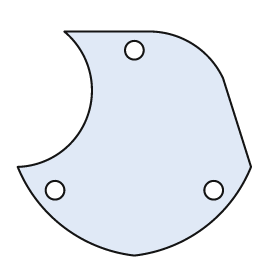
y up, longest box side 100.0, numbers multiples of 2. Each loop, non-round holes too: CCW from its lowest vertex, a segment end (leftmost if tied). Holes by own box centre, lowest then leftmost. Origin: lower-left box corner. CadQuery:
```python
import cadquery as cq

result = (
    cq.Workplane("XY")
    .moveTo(50.0, 0.0)
    .threePointArc((80.0, 12.0), (100.0, 38.0))
    .lineTo(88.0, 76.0)
    .threePointArc((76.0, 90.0), (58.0, 96.0))
    .lineTo(20.0, 96.0)
    .threePointArc((30.0, 60.0), (0.0, 38.0))
    .threePointArc((20.0, 12.0), (50.0, 0.0))
    .close()
    .moveTo(16.0, 28.0)
    .circle(4.0)
    .moveTo(84.0, 28.0)
    .circle(4.0)
    .moveTo(50.0, 88.0)
    .circle(4.0)
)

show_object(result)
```